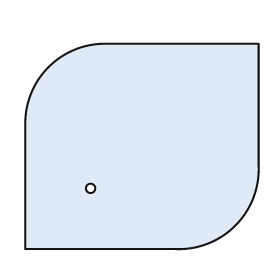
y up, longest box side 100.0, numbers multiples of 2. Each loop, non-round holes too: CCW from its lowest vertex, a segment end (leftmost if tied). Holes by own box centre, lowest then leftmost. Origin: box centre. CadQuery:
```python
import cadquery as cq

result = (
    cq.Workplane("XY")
    .moveTo(-50.0, -44.0)
    .lineTo(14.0, -44.0)
    .threePointArc((40.0, -34.0), (50.0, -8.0))
    .lineTo(50.0, 44.0)
    .lineTo(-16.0, 44.0)
    .threePointArc((-40.0, 34.0), (-50.0, 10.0))
    .close()
    .moveTo(-22.0, -18.0)
    .circle(2.0)
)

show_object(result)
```